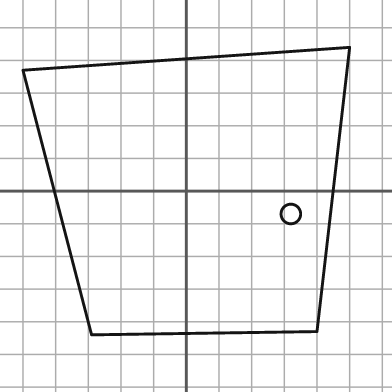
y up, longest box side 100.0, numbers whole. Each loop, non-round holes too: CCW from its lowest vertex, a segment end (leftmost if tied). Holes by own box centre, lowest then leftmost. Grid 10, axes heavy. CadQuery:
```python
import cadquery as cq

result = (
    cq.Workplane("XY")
    .moveTo(-29.0, -44.0)
    .lineTo(40.0, -43.0)
    .lineTo(50.0, 44.0)
    .lineTo(-50.0, 37.0)
    .close()
    .moveTo(32.0, -7.0)
    .circle(3.0)
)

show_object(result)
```